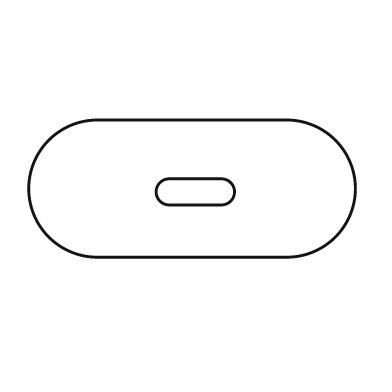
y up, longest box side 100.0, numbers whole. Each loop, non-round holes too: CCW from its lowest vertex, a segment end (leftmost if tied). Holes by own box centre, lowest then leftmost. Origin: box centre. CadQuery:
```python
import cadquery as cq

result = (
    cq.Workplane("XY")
    .moveTo(-29.0, -21.0)
    .lineTo(29.0, -21.0)
    .threePointArc((50.0, 0.0), (29.0, 21.0))
    .lineTo(-29.0, 21.0)
    .threePointArc((-50.0, 0.0), (-29.0, -21.0))
    .close()
    .moveTo(-7.0, -5.0)
    .lineTo(9.0, -5.0)
    .threePointArc((13.0, -1.0), (9.0, 3.0))
    .lineTo(-7.0, 3.0)
    .threePointArc((-11.0, -1.0), (-7.0, -5.0))
    .close()
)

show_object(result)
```